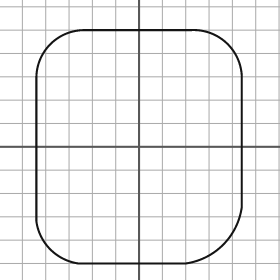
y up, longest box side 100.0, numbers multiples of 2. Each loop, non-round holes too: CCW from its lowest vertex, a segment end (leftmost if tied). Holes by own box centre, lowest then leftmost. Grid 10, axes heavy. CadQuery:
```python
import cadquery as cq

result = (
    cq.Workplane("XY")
    .moveTo(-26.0, -50.0)
    .lineTo(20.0, -50.0)
    .threePointArc((36.0, -42.0), (44.0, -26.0))
    .lineTo(44.0, 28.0)
    .threePointArc((38.0, 44.0), (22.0, 50.0))
    .lineTo(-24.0, 50.0)
    .threePointArc((-38.0, 44.0), (-44.0, 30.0))
    .lineTo(-44.0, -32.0)
    .threePointArc((-38.0, -44.0), (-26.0, -50.0))
    .close()
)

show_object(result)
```